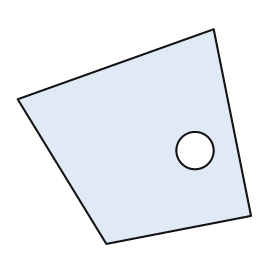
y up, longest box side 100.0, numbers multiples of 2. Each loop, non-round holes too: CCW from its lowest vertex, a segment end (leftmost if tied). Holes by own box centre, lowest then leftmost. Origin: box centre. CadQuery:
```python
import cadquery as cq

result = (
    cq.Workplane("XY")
    .moveTo(-12.0, -46.0)
    .lineTo(50.0, -34.0)
    .lineTo(34.0, 46.0)
    .lineTo(-50.0, 16.0)
    .close()
    .moveTo(26.0, -6.0)
    .circle(8.0)
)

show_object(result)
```